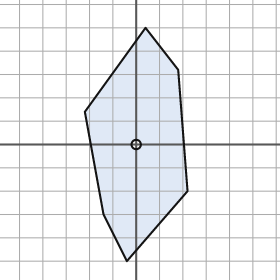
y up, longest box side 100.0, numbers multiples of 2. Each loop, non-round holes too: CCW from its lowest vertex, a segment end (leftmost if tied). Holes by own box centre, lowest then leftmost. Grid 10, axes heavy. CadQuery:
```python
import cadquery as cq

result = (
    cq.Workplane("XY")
    .moveTo(-4.0, -50.0)
    .lineTo(22.0, -20.0)
    .lineTo(18.0, 32.0)
    .lineTo(4.0, 50.0)
    .lineTo(-22.0, 14.0)
    .lineTo(-14.0, -30.0)
    .close()
    .moveTo(0.0, 0.0)
    .circle(2.0)
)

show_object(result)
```